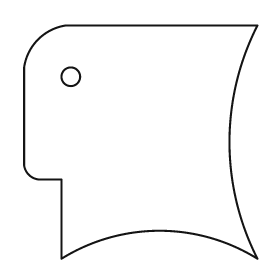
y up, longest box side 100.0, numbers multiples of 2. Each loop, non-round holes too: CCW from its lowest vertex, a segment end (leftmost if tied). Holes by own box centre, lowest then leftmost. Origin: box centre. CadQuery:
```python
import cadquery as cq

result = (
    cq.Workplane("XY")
    .moveTo(-34.0, -50.0)
    .threePointArc((8.0, -38.0), (50.0, -50.0))
    .threePointArc((38.0, 0.0), (50.0, 50.0))
    .lineTo(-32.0, 50.0)
    .threePointArc((-44.0, 44.0), (-50.0, 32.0))
    .lineTo(-50.0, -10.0)
    .threePointArc((-48.0, -14.0), (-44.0, -16.0))
    .lineTo(-34.0, -16.0)
    .close()
    .moveTo(-30.0, 28.0)
    .circle(4.0)
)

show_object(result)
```